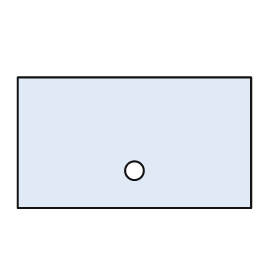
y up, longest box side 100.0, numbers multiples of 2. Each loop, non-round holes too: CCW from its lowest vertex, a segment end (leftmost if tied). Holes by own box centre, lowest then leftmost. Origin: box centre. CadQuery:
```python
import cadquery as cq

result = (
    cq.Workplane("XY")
    .moveTo(-50.0, -28.0)
    .lineTo(50.0, -28.0)
    .lineTo(50.0, 28.0)
    .lineTo(-50.0, 28.0)
    .close()
    .moveTo(0.0, -12.0)
    .circle(4.0)
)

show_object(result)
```